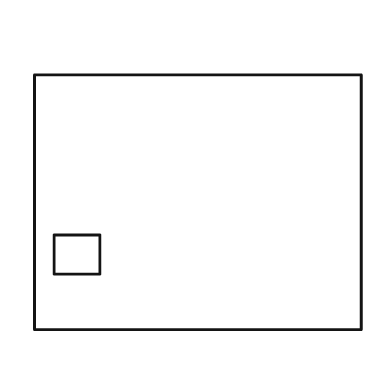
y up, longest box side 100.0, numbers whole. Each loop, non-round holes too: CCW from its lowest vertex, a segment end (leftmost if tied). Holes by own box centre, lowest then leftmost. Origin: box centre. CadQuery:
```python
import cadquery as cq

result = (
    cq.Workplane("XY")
    .moveTo(-50.0, -39.0)
    .lineTo(50.0, -39.0)
    .lineTo(50.0, 39.0)
    .lineTo(-50.0, 39.0)
    .close()
    .moveTo(-44.0, -22.0)
    .lineTo(-30.0, -22.0)
    .lineTo(-30.0, -10.0)
    .lineTo(-44.0, -10.0)
    .close()
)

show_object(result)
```